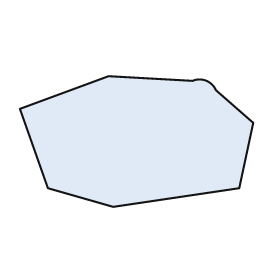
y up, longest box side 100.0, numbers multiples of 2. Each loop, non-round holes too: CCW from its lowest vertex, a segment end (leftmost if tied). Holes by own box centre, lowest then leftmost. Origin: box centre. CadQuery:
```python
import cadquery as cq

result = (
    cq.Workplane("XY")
    .moveTo(-10.0, -28.0)
    .lineTo(44.0, -20.0)
    .lineTo(50.0, 8.0)
    .lineTo(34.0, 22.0)
    .threePointArc((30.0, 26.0), (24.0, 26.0))
    .lineTo(-12.0, 28.0)
    .lineTo(-50.0, 14.0)
    .lineTo(-38.0, -20.0)
    .close()
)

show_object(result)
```